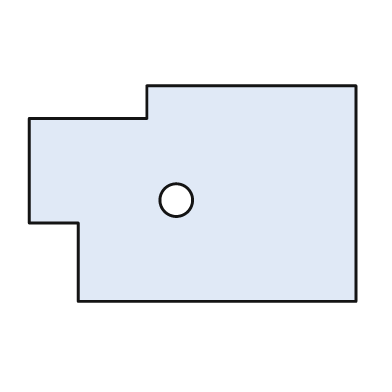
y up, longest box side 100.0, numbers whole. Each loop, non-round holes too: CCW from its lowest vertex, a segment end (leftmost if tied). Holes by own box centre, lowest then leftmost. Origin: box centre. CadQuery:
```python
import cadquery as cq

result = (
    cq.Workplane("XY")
    .moveTo(-35.0, -33.0)
    .lineTo(50.0, -33.0)
    .lineTo(50.0, 33.0)
    .lineTo(-14.0, 33.0)
    .lineTo(-14.0, 23.0)
    .lineTo(-50.0, 23.0)
    .lineTo(-50.0, -9.0)
    .lineTo(-35.0, -9.0)
    .close()
    .moveTo(-5.0, -2.0)
    .circle(5.0)
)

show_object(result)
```